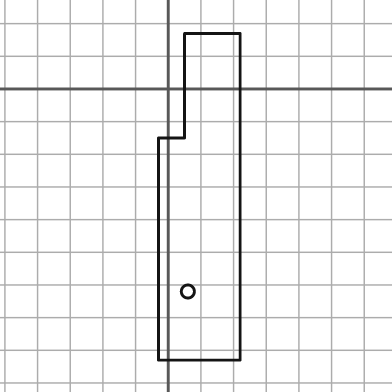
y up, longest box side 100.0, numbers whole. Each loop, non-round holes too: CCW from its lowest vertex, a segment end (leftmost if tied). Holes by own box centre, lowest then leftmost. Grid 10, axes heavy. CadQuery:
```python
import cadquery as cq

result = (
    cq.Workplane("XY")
    .moveTo(-3.0, -83.0)
    .lineTo(22.0, -83.0)
    .lineTo(22.0, 17.0)
    .lineTo(5.0, 17.0)
    .lineTo(5.0, -15.0)
    .lineTo(-3.0, -15.0)
    .close()
    .moveTo(6.0, -62.0)
    .circle(2.0)
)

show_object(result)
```